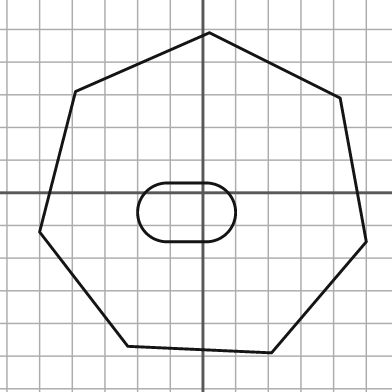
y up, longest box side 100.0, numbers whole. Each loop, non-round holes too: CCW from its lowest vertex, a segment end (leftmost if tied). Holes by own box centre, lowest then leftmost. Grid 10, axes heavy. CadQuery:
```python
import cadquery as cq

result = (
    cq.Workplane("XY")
    .moveTo(21.0, -49.0)
    .lineTo(50.0, -15.0)
    .lineTo(42.0, 29.0)
    .lineTo(2.0, 49.0)
    .lineTo(-39.0, 31.0)
    .lineTo(-50.0, -12.0)
    .lineTo(-23.0, -47.0)
    .close()
    .moveTo(-11.0, -15.0)
    .lineTo(1.0, -15.0)
    .threePointArc((10.0, -6.0), (1.0, 3.0))
    .lineTo(-11.0, 3.0)
    .threePointArc((-20.0, -6.0), (-11.0, -15.0))
    .close()
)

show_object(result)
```